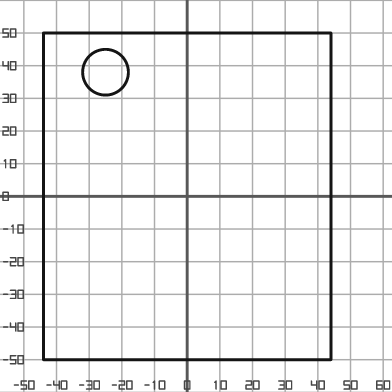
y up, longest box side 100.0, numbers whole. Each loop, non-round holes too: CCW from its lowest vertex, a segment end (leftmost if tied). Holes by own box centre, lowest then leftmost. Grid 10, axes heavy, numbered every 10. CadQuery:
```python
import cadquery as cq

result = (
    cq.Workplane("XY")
    .moveTo(-44.0, -50.0)
    .lineTo(44.0, -50.0)
    .lineTo(44.0, 50.0)
    .lineTo(-44.0, 50.0)
    .close()
    .moveTo(-25.0, 38.0)
    .circle(7.0)
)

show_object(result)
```